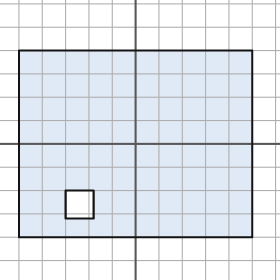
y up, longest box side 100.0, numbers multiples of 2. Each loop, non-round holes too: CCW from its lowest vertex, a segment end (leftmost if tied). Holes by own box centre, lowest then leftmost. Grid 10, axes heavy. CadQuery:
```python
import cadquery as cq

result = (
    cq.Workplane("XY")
    .moveTo(-50.0, -40.0)
    .lineTo(50.0, -40.0)
    .lineTo(50.0, 40.0)
    .lineTo(-50.0, 40.0)
    .close()
    .moveTo(-30.0, -32.0)
    .lineTo(-18.0, -32.0)
    .lineTo(-18.0, -20.0)
    .lineTo(-30.0, -20.0)
    .close()
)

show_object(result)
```